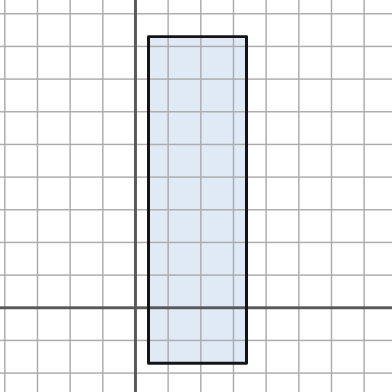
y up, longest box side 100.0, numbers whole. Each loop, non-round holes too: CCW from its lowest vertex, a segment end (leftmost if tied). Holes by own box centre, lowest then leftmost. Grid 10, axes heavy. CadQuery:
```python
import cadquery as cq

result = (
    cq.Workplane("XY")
    .moveTo(4.0, -17.0)
    .lineTo(34.0, -17.0)
    .lineTo(34.0, 83.0)
    .lineTo(4.0, 83.0)
    .close()
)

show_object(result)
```